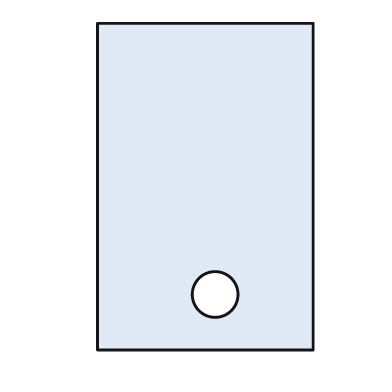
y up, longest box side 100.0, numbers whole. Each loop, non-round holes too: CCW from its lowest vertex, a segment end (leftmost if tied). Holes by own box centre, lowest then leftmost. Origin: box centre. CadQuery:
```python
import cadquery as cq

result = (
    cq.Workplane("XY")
    .moveTo(-33.0, -50.0)
    .lineTo(33.0, -50.0)
    .lineTo(33.0, 50.0)
    .lineTo(-33.0, 50.0)
    .close()
    .moveTo(3.0, -33.0)
    .circle(7.0)
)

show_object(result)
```